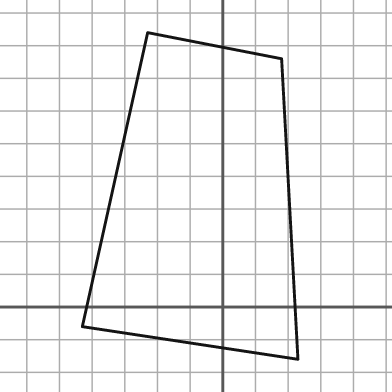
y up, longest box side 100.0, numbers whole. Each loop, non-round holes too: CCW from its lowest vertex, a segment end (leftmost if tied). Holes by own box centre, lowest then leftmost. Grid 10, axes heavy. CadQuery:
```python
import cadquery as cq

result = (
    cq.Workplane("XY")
    .moveTo(23.0, -16.0)
    .lineTo(18.0, 76.0)
    .lineTo(-23.0, 84.0)
    .lineTo(-43.0, -6.0)
    .close()
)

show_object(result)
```